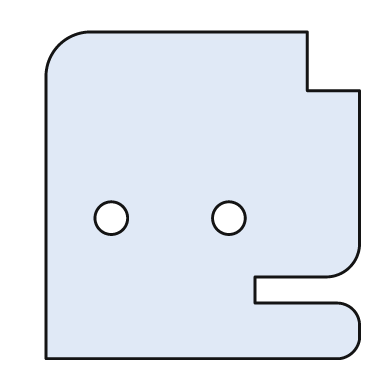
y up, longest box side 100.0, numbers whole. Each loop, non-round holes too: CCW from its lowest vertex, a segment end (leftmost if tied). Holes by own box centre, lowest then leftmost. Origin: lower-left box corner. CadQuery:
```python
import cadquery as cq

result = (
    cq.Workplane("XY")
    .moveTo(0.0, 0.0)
    .lineTo(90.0, 0.0)
    .threePointArc((94.0, 2.0), (96.0, 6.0))
    .lineTo(96.0, 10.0)
    .threePointArc((94.0, 15.0), (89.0, 17.0))
    .lineTo(64.0, 17.0)
    .lineTo(64.0, 25.0)
    .lineTo(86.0, 25.0)
    .threePointArc((93.0, 28.0), (96.0, 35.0))
    .lineTo(96.0, 82.0)
    .lineTo(80.0, 82.0)
    .lineTo(80.0, 100.0)
    .lineTo(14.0, 100.0)
    .threePointArc((4.0, 96.0), (0.0, 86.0))
    .close()
    .moveTo(20.0, 43.0)
    .circle(5.0)
    .moveTo(56.0, 43.0)
    .circle(5.0)
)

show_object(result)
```